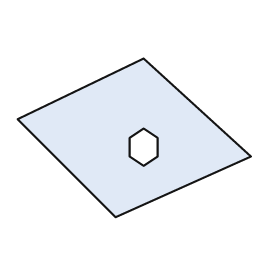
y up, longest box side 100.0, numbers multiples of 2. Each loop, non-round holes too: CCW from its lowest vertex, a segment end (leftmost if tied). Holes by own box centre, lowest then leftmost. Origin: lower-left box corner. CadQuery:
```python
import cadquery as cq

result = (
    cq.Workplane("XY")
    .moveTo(42.0, 0.0)
    .lineTo(100.0, 26.0)
    .lineTo(54.0, 68.0)
    .lineTo(0.0, 42.0)
    .close()
    .moveTo(54.0, 22.0)
    .lineTo(60.0, 26.0)
    .lineTo(60.0, 34.0)
    .lineTo(54.0, 38.0)
    .lineTo(48.0, 34.0)
    .lineTo(48.0, 26.0)
    .close()
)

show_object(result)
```